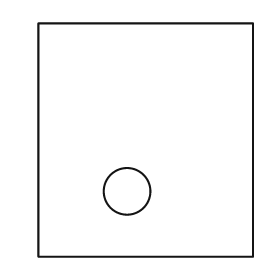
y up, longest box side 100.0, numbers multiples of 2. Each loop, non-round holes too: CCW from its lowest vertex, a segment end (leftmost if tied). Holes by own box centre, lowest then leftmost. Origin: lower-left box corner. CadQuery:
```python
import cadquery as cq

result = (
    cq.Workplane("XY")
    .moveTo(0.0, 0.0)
    .lineTo(92.0, 0.0)
    .lineTo(92.0, 100.0)
    .lineTo(0.0, 100.0)
    .close()
    .moveTo(38.0, 28.0)
    .circle(10.0)
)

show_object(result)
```